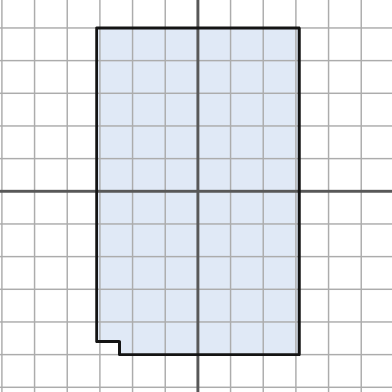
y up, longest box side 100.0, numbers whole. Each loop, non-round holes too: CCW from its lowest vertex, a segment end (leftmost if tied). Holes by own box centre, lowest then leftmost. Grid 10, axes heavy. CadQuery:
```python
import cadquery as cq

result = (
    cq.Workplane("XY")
    .moveTo(-24.0, -50.0)
    .lineTo(31.0, -50.0)
    .lineTo(31.0, 50.0)
    .lineTo(-31.0, 50.0)
    .lineTo(-31.0, -46.0)
    .lineTo(-24.0, -46.0)
    .close()
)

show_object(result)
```